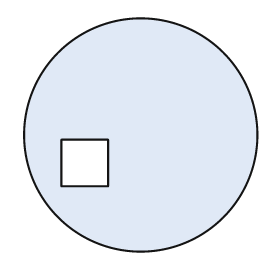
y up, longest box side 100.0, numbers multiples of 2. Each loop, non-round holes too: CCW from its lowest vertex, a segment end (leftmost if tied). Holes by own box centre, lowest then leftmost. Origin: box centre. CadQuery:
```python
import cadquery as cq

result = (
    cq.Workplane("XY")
    .moveTo(0.0, 0.0)
    .circle(50.0)
    .moveTo(-34.0, -22.0)
    .lineTo(-14.0, -22.0)
    .lineTo(-14.0, -2.0)
    .lineTo(-34.0, -2.0)
    .close()
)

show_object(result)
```